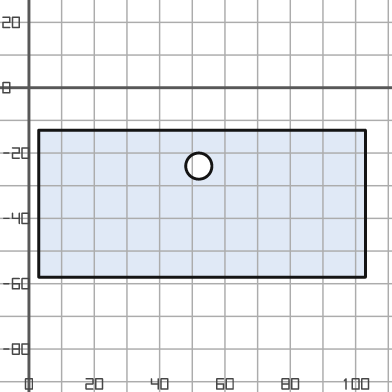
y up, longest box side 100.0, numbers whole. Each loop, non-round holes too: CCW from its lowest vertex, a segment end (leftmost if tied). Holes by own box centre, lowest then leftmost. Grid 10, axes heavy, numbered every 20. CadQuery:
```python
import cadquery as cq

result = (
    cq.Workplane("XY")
    .moveTo(3.0, -58.0)
    .lineTo(103.0, -58.0)
    .lineTo(103.0, -13.0)
    .lineTo(3.0, -13.0)
    .close()
    .moveTo(52.0, -24.0)
    .circle(4.0)
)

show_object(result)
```